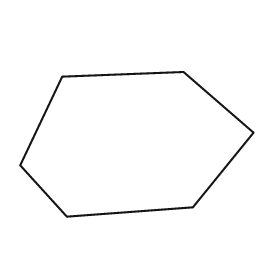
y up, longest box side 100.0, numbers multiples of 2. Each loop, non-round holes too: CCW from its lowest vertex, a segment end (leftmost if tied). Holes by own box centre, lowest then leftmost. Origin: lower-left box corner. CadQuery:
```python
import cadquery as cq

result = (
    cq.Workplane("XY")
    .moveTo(20.0, 0.0)
    .lineTo(74.0, 4.0)
    .lineTo(100.0, 36.0)
    .lineTo(70.0, 62.0)
    .lineTo(18.0, 60.0)
    .lineTo(0.0, 22.0)
    .close()
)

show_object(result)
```